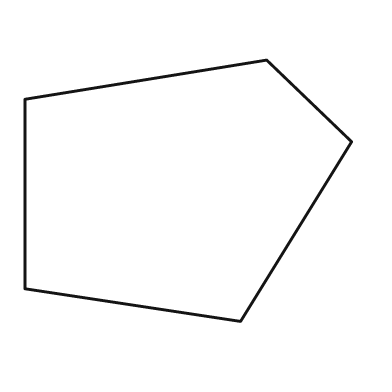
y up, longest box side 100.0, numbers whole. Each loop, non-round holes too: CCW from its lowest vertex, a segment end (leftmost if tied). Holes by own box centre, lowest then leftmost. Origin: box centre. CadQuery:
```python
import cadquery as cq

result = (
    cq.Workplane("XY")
    .moveTo(16.0, -40.0)
    .lineTo(50.0, 15.0)
    .lineTo(24.0, 40.0)
    .lineTo(-50.0, 28.0)
    .lineTo(-50.0, -30.0)
    .close()
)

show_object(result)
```